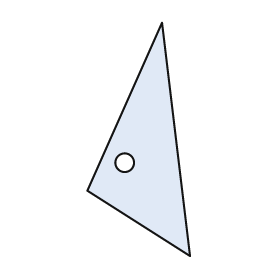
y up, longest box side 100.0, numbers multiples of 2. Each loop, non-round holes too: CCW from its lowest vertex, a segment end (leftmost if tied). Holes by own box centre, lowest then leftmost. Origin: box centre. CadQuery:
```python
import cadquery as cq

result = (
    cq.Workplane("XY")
    .moveTo(22.0, -50.0)
    .lineTo(10.0, 50.0)
    .lineTo(-22.0, -22.0)
    .close()
    .moveTo(-6.0, -10.0)
    .circle(4.0)
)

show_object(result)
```